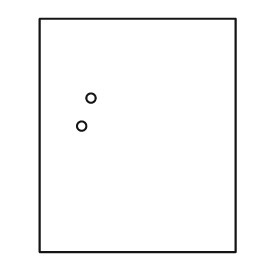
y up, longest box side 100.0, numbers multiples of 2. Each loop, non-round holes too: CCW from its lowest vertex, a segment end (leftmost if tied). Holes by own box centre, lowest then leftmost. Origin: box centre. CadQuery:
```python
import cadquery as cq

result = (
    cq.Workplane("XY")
    .moveTo(-42.0, -50.0)
    .lineTo(42.0, -50.0)
    .lineTo(42.0, 50.0)
    .lineTo(-42.0, 50.0)
    .close()
    .moveTo(-24.0, 4.0)
    .circle(2.0)
    .moveTo(-20.0, 16.0)
    .circle(2.0)
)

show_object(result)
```